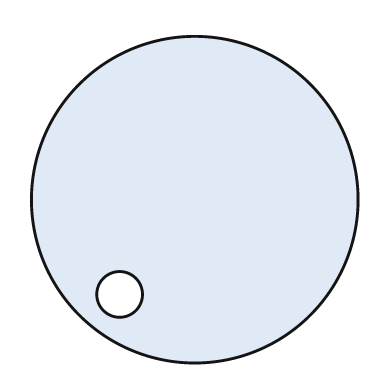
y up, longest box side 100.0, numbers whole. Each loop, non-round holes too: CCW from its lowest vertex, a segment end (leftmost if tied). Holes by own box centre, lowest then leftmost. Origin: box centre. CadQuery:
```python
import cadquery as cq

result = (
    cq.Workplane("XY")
    .moveTo(0.0, 0.0)
    .circle(50.0)
    .moveTo(-23.0, -29.0)
    .circle(7.0)
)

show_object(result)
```